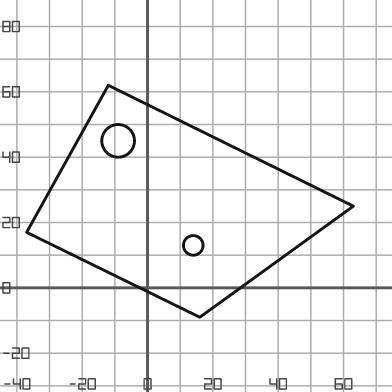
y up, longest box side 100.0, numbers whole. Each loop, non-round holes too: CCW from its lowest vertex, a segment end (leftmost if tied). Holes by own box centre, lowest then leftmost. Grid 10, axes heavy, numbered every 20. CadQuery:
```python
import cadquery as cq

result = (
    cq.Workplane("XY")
    .moveTo(16.0, -9.0)
    .lineTo(63.0, 25.0)
    .lineTo(-12.0, 62.0)
    .lineTo(-37.0, 17.0)
    .close()
    .moveTo(14.0, 13.0)
    .circle(3.0)
    .moveTo(-9.0, 45.0)
    .circle(5.0)
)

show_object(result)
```